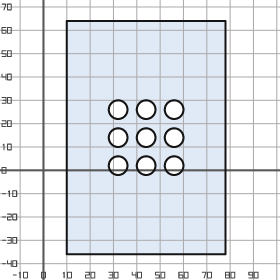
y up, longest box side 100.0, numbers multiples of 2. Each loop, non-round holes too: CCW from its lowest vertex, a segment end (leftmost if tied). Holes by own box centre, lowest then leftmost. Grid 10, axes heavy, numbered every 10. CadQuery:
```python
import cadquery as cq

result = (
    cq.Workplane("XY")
    .moveTo(10.0, -36.0)
    .lineTo(78.0, -36.0)
    .lineTo(78.0, 64.0)
    .lineTo(10.0, 64.0)
    .close()
    .moveTo(32.0, 2.0)
    .circle(4.0)
    .moveTo(44.0, 2.0)
    .circle(4.0)
    .moveTo(56.0, 2.0)
    .circle(4.0)
    .moveTo(32.0, 14.0)
    .circle(4.0)
    .moveTo(44.0, 14.0)
    .circle(4.0)
    .moveTo(56.0, 14.0)
    .circle(4.0)
    .moveTo(32.0, 26.0)
    .circle(4.0)
    .moveTo(44.0, 26.0)
    .circle(4.0)
    .moveTo(56.0, 26.0)
    .circle(4.0)
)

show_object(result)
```